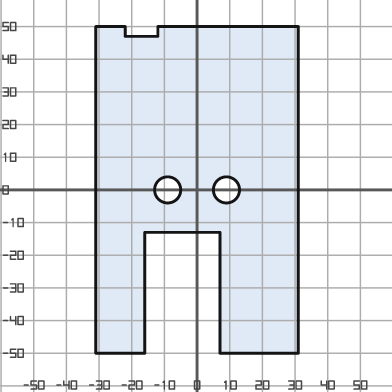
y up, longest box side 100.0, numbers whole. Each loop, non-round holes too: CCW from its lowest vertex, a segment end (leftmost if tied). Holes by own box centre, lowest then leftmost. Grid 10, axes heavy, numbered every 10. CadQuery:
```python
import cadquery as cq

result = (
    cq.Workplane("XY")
    .moveTo(-31.0, -50.0)
    .lineTo(-16.0, -50.0)
    .lineTo(-16.0, -13.0)
    .lineTo(7.0, -13.0)
    .lineTo(7.0, -50.0)
    .lineTo(31.0, -50.0)
    .lineTo(31.0, 50.0)
    .lineTo(-12.0, 50.0)
    .lineTo(-12.0, 47.0)
    .lineTo(-22.0, 47.0)
    .lineTo(-22.0, 50.0)
    .lineTo(-31.0, 50.0)
    .close()
    .moveTo(-9.0, 0.0)
    .circle(4.0)
    .moveTo(9.0, 0.0)
    .circle(4.0)
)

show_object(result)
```